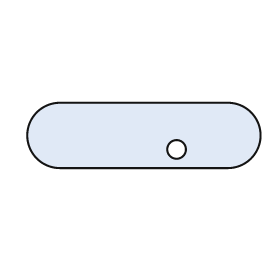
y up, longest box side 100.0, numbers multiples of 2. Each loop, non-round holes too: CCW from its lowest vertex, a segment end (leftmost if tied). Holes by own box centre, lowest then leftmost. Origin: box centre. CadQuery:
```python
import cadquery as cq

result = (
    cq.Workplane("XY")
    .moveTo(-36.0, -14.0)
    .lineTo(36.0, -14.0)
    .threePointArc((50.0, 0.0), (36.0, 14.0))
    .lineTo(-36.0, 14.0)
    .threePointArc((-50.0, 0.0), (-36.0, -14.0))
    .close()
    .moveTo(14.0, -6.0)
    .circle(4.0)
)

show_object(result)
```